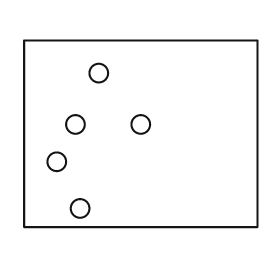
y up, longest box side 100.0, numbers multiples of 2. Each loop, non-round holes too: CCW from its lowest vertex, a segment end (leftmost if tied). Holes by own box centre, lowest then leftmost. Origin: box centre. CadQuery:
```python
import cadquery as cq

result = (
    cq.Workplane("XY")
    .moveTo(-50.0, -40.0)
    .lineTo(50.0, -40.0)
    .lineTo(50.0, 40.0)
    .lineTo(-50.0, 40.0)
    .close()
    .moveTo(-26.0, -32.0)
    .circle(4.0)
    .moveTo(-36.0, -12.0)
    .circle(4.0)
    .moveTo(-28.0, 4.0)
    .circle(4.0)
    .moveTo(0.0, 4.0)
    .circle(4.0)
    .moveTo(-18.0, 26.0)
    .circle(4.0)
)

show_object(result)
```